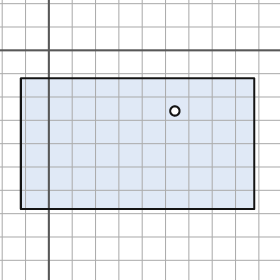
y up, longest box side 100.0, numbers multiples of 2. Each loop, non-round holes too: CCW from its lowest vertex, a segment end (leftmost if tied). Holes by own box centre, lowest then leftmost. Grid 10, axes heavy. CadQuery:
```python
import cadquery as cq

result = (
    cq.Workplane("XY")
    .moveTo(-12.0, -68.0)
    .lineTo(88.0, -68.0)
    .lineTo(88.0, -12.0)
    .lineTo(-12.0, -12.0)
    .close()
    .moveTo(54.0, -26.0)
    .circle(2.0)
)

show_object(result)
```